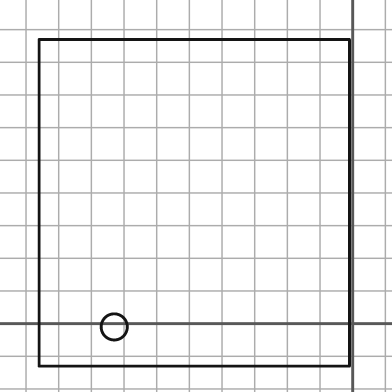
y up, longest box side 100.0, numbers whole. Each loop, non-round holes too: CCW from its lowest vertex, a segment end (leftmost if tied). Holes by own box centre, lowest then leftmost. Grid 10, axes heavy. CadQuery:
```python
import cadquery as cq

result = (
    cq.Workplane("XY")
    .moveTo(-96.0, -13.0)
    .lineTo(-1.0, -13.0)
    .lineTo(-1.0, 87.0)
    .lineTo(-96.0, 87.0)
    .close()
    .moveTo(-73.0, -1.0)
    .circle(4.0)
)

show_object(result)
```